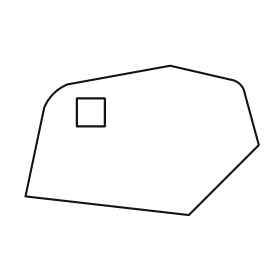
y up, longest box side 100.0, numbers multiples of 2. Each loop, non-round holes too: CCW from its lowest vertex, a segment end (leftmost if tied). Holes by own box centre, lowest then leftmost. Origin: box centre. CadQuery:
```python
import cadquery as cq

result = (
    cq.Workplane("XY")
    .moveTo(20.0, -32.0)
    .lineTo(50.0, -2.0)
    .lineTo(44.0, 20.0)
    .threePointArc((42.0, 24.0), (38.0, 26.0))
    .lineTo(12.0, 32.0)
    .lineTo(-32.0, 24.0)
    .threePointArc((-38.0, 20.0), (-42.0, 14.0))
    .lineTo(-50.0, -24.0)
    .close()
    .moveTo(-28.0, 6.0)
    .lineTo(-16.0, 6.0)
    .lineTo(-16.0, 18.0)
    .lineTo(-28.0, 18.0)
    .close()
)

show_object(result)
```